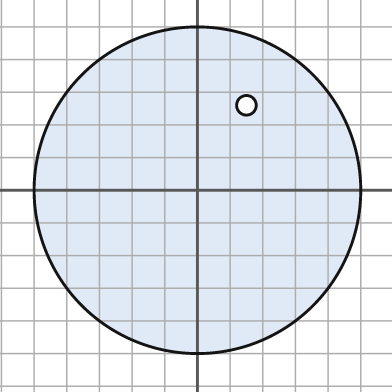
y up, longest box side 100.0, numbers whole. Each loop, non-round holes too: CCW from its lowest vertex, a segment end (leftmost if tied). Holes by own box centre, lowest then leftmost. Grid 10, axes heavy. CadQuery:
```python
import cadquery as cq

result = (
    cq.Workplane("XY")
    .moveTo(0.0, 0.0)
    .circle(50.0)
    .moveTo(15.0, 26.0)
    .circle(3.0)
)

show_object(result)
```